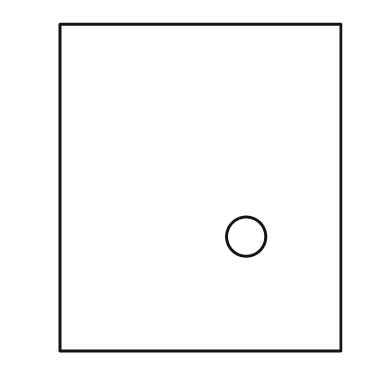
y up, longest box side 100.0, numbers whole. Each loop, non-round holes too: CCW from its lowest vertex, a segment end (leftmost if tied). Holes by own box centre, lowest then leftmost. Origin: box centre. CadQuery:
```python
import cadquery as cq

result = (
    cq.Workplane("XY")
    .moveTo(-43.0, -50.0)
    .lineTo(43.0, -50.0)
    .lineTo(43.0, 50.0)
    .lineTo(-43.0, 50.0)
    .close()
    .moveTo(14.0, -15.0)
    .circle(6.0)
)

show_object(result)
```